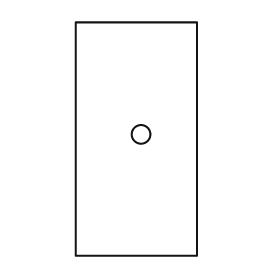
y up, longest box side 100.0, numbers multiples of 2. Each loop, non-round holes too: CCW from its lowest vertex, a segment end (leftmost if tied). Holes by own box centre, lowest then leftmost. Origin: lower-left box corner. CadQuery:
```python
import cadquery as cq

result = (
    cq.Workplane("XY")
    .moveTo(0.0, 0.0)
    .lineTo(52.0, 0.0)
    .lineTo(52.0, 100.0)
    .lineTo(0.0, 100.0)
    .close()
    .moveTo(28.0, 52.0)
    .circle(4.0)
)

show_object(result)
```